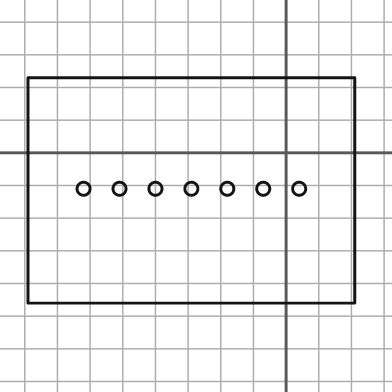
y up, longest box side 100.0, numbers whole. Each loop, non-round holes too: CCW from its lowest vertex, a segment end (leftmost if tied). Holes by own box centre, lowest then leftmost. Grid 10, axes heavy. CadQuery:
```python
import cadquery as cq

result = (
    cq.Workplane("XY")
    .moveTo(-79.0, -46.0)
    .lineTo(21.0, -46.0)
    .lineTo(21.0, 23.0)
    .lineTo(-79.0, 23.0)
    .close()
    .moveTo(-62.0, -11.0)
    .circle(2.0)
    .moveTo(-51.0, -11.0)
    .circle(2.0)
    .moveTo(-40.0, -11.0)
    .circle(2.0)
    .moveTo(-29.0, -11.0)
    .circle(2.0)
    .moveTo(-18.0, -11.0)
    .circle(2.0)
    .moveTo(-7.0, -11.0)
    .circle(2.0)
    .moveTo(4.0, -11.0)
    .circle(2.0)
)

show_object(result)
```